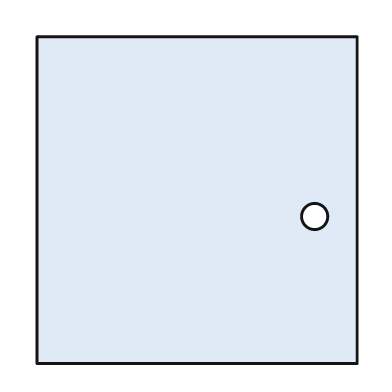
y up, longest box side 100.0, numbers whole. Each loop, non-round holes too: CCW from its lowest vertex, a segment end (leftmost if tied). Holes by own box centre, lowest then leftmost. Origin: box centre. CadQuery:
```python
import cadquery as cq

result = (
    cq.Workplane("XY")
    .moveTo(-49.0, -50.0)
    .lineTo(49.0, -50.0)
    .lineTo(49.0, 50.0)
    .lineTo(-49.0, 50.0)
    .close()
    .moveTo(36.0, -5.0)
    .circle(4.0)
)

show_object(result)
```